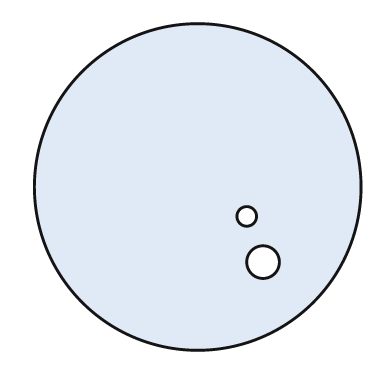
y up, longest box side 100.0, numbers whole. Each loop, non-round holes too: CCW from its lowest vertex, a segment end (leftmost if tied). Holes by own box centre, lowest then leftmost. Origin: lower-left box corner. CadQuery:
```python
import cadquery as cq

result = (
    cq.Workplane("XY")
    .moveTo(50.0, 50.0)
    .circle(50.0)
    .moveTo(70.0, 27.0)
    .circle(5.0)
    .moveTo(65.0, 41.0)
    .circle(3.0)
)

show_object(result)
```